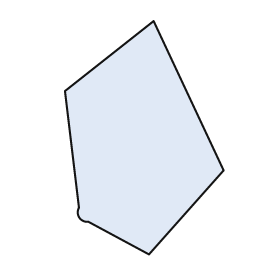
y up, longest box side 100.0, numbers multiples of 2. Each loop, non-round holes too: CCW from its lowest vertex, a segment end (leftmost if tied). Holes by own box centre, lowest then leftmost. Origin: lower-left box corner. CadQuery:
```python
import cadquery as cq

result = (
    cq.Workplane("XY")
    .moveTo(36.0, 0.0)
    .lineTo(68.0, 36.0)
    .lineTo(38.0, 100.0)
    .lineTo(0.0, 70.0)
    .lineTo(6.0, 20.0)
    .threePointArc((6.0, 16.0), (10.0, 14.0))
    .close()
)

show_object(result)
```